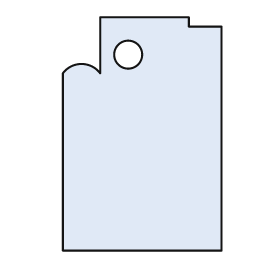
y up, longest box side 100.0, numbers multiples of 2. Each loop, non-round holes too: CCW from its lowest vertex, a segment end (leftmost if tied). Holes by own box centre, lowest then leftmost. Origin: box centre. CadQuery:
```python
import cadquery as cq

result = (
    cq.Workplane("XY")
    .moveTo(-34.0, -50.0)
    .lineTo(34.0, -50.0)
    .lineTo(34.0, 46.0)
    .lineTo(20.0, 46.0)
    .lineTo(20.0, 50.0)
    .lineTo(-18.0, 50.0)
    .lineTo(-18.0, 26.0)
    .threePointArc((-26.0, 30.0), (-34.0, 26.0))
    .close()
    .moveTo(-6.0, 34.0)
    .circle(6.0)
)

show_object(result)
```